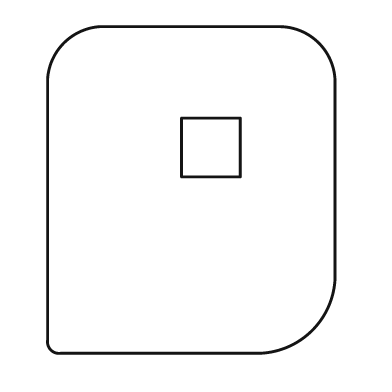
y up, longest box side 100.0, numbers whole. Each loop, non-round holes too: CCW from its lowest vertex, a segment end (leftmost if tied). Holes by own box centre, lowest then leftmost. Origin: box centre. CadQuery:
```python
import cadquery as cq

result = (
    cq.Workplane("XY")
    .moveTo(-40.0, -50.0)
    .lineTo(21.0, -50.0)
    .threePointArc((37.0, -43.0), (44.0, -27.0))
    .lineTo(44.0, 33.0)
    .threePointArc((39.0, 45.0), (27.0, 50.0))
    .lineTo(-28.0, 50.0)
    .threePointArc((-39.0, 45.0), (-44.0, 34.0))
    .lineTo(-44.0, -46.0)
    .threePointArc((-43.0, -49.0), (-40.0, -50.0))
    .close()
    .moveTo(-3.0, 4.0)
    .lineTo(15.0, 4.0)
    .lineTo(15.0, 22.0)
    .lineTo(-3.0, 22.0)
    .close()
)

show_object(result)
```